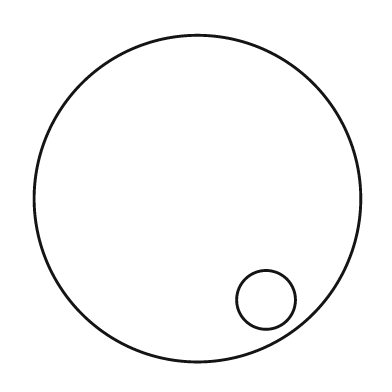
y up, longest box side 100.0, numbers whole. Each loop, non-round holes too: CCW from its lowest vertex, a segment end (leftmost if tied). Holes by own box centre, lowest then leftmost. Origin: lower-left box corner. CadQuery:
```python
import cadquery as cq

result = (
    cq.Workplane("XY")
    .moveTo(50.0, 50.0)
    .circle(50.0)
    .moveTo(71.0, 19.0)
    .circle(9.0)
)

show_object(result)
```